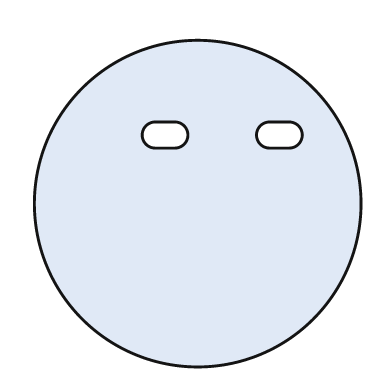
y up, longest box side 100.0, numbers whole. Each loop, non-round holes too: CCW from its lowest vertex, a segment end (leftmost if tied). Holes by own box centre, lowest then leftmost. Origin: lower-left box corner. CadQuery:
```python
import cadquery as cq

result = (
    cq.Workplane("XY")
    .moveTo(50.0, 50.0)
    .circle(50.0)
    .moveTo(37.0, 67.0)
    .lineTo(43.0, 67.0)
    .threePointArc((47.0, 71.0), (43.0, 75.0))
    .lineTo(37.0, 75.0)
    .threePointArc((33.0, 71.0), (37.0, 67.0))
    .close()
    .moveTo(72.0, 67.0)
    .lineTo(78.0, 67.0)
    .threePointArc((82.0, 71.0), (78.0, 75.0))
    .lineTo(72.0, 75.0)
    .threePointArc((68.0, 71.0), (72.0, 67.0))
    .close()
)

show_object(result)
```